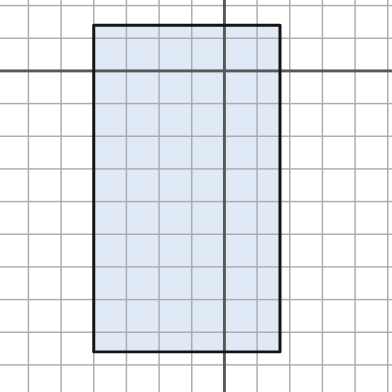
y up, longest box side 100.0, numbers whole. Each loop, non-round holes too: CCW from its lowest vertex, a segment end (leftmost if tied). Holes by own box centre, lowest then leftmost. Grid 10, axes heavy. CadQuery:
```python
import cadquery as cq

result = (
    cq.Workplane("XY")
    .moveTo(-40.0, -86.0)
    .lineTo(17.0, -86.0)
    .lineTo(17.0, 14.0)
    .lineTo(-40.0, 14.0)
    .close()
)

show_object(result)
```